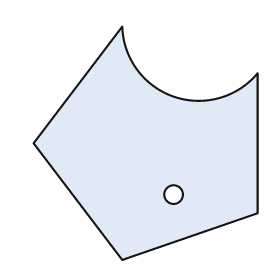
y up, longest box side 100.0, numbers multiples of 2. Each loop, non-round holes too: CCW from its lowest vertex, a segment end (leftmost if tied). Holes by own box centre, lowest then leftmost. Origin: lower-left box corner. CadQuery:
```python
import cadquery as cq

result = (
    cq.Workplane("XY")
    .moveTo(38.0, 0.0)
    .lineTo(96.0, 20.0)
    .lineTo(96.0, 80.0)
    .threePointArc((60.0, 70.0), (38.0, 100.0))
    .lineTo(0.0, 50.0)
    .close()
    .moveTo(60.0, 28.0)
    .circle(4.0)
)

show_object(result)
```